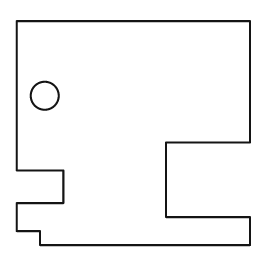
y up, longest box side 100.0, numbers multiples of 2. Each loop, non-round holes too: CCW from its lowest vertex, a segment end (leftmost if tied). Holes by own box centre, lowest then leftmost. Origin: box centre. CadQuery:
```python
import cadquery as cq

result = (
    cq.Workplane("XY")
    .moveTo(-40.0, -48.0)
    .lineTo(50.0, -48.0)
    .lineTo(50.0, -36.0)
    .lineTo(14.0, -36.0)
    .lineTo(14.0, -4.0)
    .lineTo(50.0, -4.0)
    .lineTo(50.0, 48.0)
    .lineTo(-50.0, 48.0)
    .lineTo(-50.0, -16.0)
    .lineTo(-30.0, -16.0)
    .lineTo(-30.0, -30.0)
    .lineTo(-50.0, -30.0)
    .lineTo(-50.0, -42.0)
    .lineTo(-40.0, -42.0)
    .close()
    .moveTo(-38.0, 16.0)
    .circle(6.0)
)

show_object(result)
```